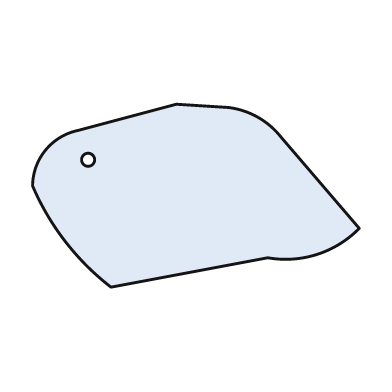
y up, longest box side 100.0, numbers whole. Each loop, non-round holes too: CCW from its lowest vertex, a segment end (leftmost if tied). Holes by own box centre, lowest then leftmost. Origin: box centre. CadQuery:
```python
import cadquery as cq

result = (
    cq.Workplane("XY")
    .moveTo(-26.0, -28.0)
    .lineTo(22.0, -19.0)
    .threePointArc((37.0, -18.0), (50.0, -10.0))
    .lineTo(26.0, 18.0)
    .threePointArc((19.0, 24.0), (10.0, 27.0))
    .lineTo(-6.0, 28.0)
    .lineTo(-36.0, 20.0)
    .threePointArc((-46.0, 14.0), (-50.0, 3.0))
    .threePointArc((-40.0, -14.0), (-26.0, -28.0))
    .close()
    .moveTo(-33.0, 11.0)
    .circle(2.0)
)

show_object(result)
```